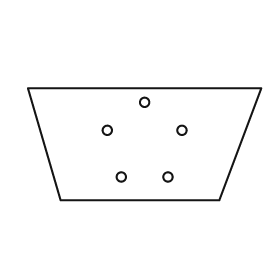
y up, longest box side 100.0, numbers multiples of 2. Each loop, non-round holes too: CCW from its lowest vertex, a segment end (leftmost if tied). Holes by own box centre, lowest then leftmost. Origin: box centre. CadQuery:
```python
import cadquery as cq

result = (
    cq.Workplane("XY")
    .moveTo(-36.0, -24.0)
    .lineTo(32.0, -24.0)
    .lineTo(50.0, 24.0)
    .lineTo(-50.0, 24.0)
    .close()
    .moveTo(-10.0, -14.0)
    .circle(2.0)
    .moveTo(10.0, -14.0)
    .circle(2.0)
    .moveTo(-16.0, 6.0)
    .circle(2.0)
    .moveTo(16.0, 6.0)
    .circle(2.0)
    .moveTo(0.0, 18.0)
    .circle(2.0)
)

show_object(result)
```